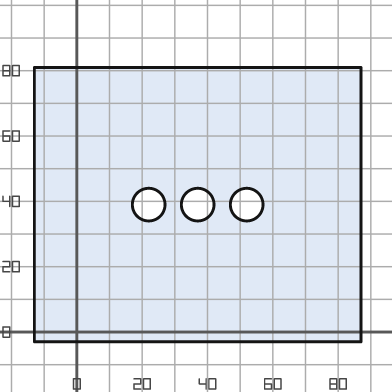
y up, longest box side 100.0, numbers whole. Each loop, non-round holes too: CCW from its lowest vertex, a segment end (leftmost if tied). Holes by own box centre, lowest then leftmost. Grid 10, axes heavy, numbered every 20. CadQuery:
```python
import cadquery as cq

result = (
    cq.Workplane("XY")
    .moveTo(-13.0, -3.0)
    .lineTo(87.0, -3.0)
    .lineTo(87.0, 81.0)
    .lineTo(-13.0, 81.0)
    .close()
    .moveTo(22.0, 39.0)
    .circle(5.0)
    .moveTo(37.0, 39.0)
    .circle(5.0)
    .moveTo(52.0, 39.0)
    .circle(5.0)
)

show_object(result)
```